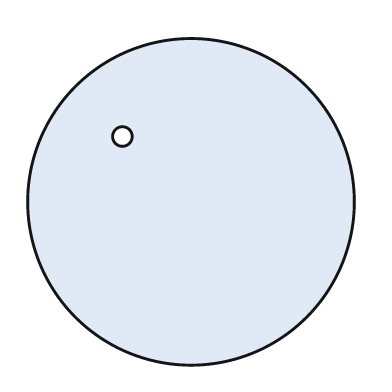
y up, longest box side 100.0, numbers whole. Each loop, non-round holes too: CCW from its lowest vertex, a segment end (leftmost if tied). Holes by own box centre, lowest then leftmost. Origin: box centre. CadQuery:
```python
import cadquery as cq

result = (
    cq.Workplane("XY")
    .moveTo(0.0, 0.0)
    .circle(50.0)
    .moveTo(-21.0, 20.0)
    .circle(3.0)
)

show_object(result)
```